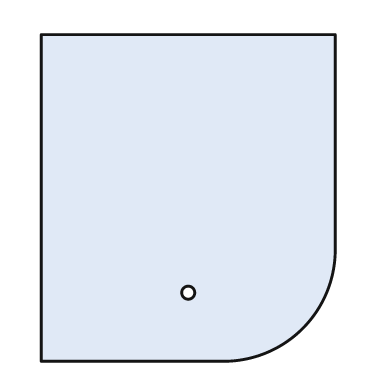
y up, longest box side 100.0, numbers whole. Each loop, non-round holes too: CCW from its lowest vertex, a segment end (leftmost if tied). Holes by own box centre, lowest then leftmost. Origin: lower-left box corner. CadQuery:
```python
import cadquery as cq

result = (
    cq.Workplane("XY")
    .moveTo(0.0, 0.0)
    .lineTo(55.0, 0.0)
    .threePointArc((80.0, 10.0), (90.0, 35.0))
    .lineTo(90.0, 100.0)
    .lineTo(0.0, 100.0)
    .close()
    .moveTo(45.0, 21.0)
    .circle(2.0)
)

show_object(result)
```